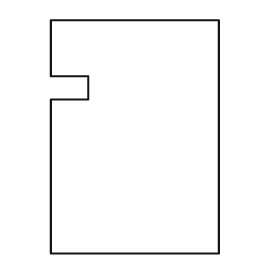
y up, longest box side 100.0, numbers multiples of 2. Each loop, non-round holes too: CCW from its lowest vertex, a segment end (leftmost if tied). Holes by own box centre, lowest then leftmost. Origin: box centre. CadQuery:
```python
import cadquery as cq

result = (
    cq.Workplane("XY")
    .moveTo(-36.0, -50.0)
    .lineTo(36.0, -50.0)
    .lineTo(36.0, 50.0)
    .lineTo(-36.0, 50.0)
    .lineTo(-36.0, 26.0)
    .lineTo(-20.0, 26.0)
    .lineTo(-20.0, 16.0)
    .lineTo(-36.0, 16.0)
    .close()
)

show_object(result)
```